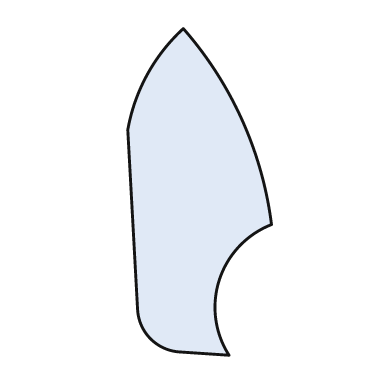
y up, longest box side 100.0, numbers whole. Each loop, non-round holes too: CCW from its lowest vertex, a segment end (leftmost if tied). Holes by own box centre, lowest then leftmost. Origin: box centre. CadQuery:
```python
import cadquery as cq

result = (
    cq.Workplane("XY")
    .moveTo(9.0, -50.0)
    .threePointArc((6.0, -27.0), (22.0, -10.0))
    .threePointArc((13.0, 22.0), (-5.0, 50.0))
    .threePointArc((-16.0, 36.0), (-22.0, 19.0))
    .lineTo(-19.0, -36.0)
    .threePointArc((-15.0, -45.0), (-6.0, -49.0))
    .close()
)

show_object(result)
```